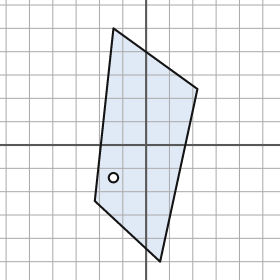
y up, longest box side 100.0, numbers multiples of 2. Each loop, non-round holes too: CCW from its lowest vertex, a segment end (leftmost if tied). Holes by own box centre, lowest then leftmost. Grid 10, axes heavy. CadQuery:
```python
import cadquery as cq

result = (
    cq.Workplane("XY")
    .moveTo(6.0, -50.0)
    .lineTo(22.0, 24.0)
    .lineTo(-14.0, 50.0)
    .lineTo(-22.0, -24.0)
    .close()
    .moveTo(-14.0, -14.0)
    .circle(2.0)
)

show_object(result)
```